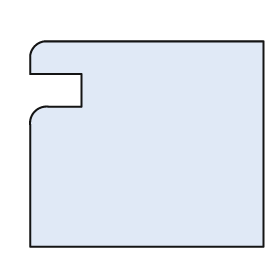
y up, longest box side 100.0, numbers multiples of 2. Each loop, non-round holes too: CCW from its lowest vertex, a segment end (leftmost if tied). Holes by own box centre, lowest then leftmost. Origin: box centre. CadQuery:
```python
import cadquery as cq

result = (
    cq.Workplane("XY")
    .moveTo(-50.0, -44.0)
    .lineTo(50.0, -44.0)
    .lineTo(50.0, 44.0)
    .lineTo(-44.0, 44.0)
    .threePointArc((-48.0, 42.0), (-50.0, 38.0))
    .lineTo(-50.0, 30.0)
    .lineTo(-28.0, 30.0)
    .lineTo(-28.0, 16.0)
    .lineTo(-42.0, 16.0)
    .threePointArc((-48.0, 14.0), (-50.0, 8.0))
    .close()
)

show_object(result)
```